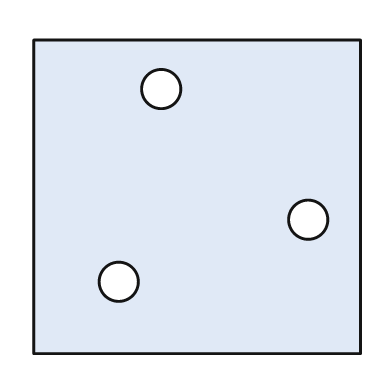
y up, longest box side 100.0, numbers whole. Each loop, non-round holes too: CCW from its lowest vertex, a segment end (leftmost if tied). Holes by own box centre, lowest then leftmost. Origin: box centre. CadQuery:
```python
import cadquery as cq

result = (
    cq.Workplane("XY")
    .moveTo(-50.0, -48.0)
    .lineTo(50.0, -48.0)
    .lineTo(50.0, 48.0)
    .lineTo(-50.0, 48.0)
    .close()
    .moveTo(-24.0, -26.0)
    .circle(6.0)
    .moveTo(34.0, -7.0)
    .circle(6.0)
    .moveTo(-11.0, 33.0)
    .circle(6.0)
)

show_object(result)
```